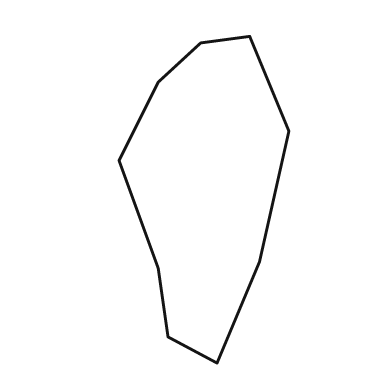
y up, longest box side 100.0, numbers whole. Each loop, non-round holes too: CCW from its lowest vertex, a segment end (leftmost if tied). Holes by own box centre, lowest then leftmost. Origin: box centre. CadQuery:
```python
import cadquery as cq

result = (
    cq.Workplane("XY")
    .moveTo(4.0, -50.0)
    .lineTo(17.0, -19.0)
    .lineTo(26.0, 21.0)
    .lineTo(14.0, 50.0)
    .lineTo(-1.0, 48.0)
    .lineTo(-14.0, 36.0)
    .lineTo(-26.0, 12.0)
    .lineTo(-14.0, -21.0)
    .lineTo(-11.0, -42.0)
    .close()
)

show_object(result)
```